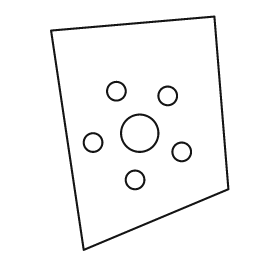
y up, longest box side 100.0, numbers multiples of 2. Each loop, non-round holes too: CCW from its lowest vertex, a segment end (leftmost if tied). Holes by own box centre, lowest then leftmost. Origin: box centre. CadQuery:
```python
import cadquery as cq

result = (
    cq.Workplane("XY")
    .moveTo(-24.0, -50.0)
    .lineTo(38.0, -24.0)
    .lineTo(32.0, 50.0)
    .lineTo(-38.0, 44.0)
    .close()
    .moveTo(-2.0, -20.0)
    .circle(4.0)
    .moveTo(18.0, -8.0)
    .circle(4.0)
    .moveTo(-20.0, -4.0)
    .circle(4.0)
    .moveTo(0.0, 0.0)
    .circle(8.0)
    .moveTo(12.0, 16.0)
    .circle(4.0)
    .moveTo(-10.0, 18.0)
    .circle(4.0)
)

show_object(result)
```